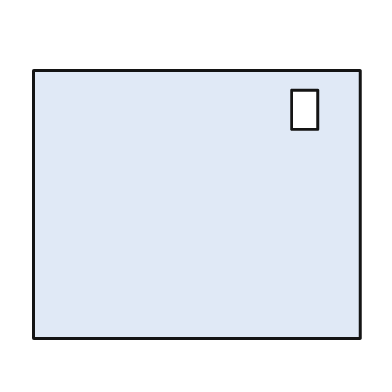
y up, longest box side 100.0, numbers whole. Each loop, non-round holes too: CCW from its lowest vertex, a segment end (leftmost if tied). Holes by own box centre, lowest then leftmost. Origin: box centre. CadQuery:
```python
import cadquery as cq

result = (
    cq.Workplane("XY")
    .moveTo(-50.0, -41.0)
    .lineTo(50.0, -41.0)
    .lineTo(50.0, 41.0)
    .lineTo(-50.0, 41.0)
    .close()
    .moveTo(29.0, 23.0)
    .lineTo(37.0, 23.0)
    .lineTo(37.0, 35.0)
    .lineTo(29.0, 35.0)
    .close()
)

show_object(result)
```